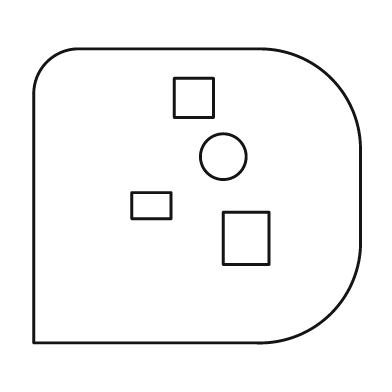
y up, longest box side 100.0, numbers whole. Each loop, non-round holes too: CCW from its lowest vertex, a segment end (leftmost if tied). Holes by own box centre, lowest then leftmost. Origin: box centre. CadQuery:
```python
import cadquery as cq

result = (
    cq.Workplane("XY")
    .moveTo(-50.0, -45.0)
    .lineTo(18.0, -45.0)
    .threePointArc((41.0, -36.0), (50.0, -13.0))
    .lineTo(50.0, 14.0)
    .threePointArc((41.0, 36.0), (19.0, 45.0))
    .lineTo(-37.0, 45.0)
    .threePointArc((-46.0, 41.0), (-50.0, 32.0))
    .close()
    .moveTo(8.0, -21.0)
    .lineTo(22.0, -21.0)
    .lineTo(22.0, -5.0)
    .lineTo(8.0, -5.0)
    .close()
    .moveTo(-20.0, -7.0)
    .lineTo(-8.0, -7.0)
    .lineTo(-8.0, 1.0)
    .lineTo(-20.0, 1.0)
    .close()
    .moveTo(8.0, 12.0)
    .circle(7.0)
    .moveTo(-7.0, 24.0)
    .lineTo(5.0, 24.0)
    .lineTo(5.0, 36.0)
    .lineTo(-7.0, 36.0)
    .close()
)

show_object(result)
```